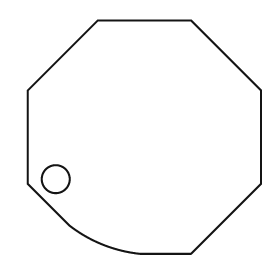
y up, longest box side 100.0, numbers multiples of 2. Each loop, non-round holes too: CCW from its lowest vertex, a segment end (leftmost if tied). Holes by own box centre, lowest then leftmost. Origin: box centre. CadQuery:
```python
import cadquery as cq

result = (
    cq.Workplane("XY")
    .moveTo(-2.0, -50.0)
    .lineTo(20.0, -50.0)
    .lineTo(50.0, -20.0)
    .lineTo(50.0, 20.0)
    .lineTo(20.0, 50.0)
    .lineTo(-20.0, 50.0)
    .lineTo(-50.0, 20.0)
    .lineTo(-50.0, -20.0)
    .lineTo(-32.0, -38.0)
    .threePointArc((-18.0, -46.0), (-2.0, -50.0))
    .close()
    .moveTo(-38.0, -18.0)
    .circle(6.0)
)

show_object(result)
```